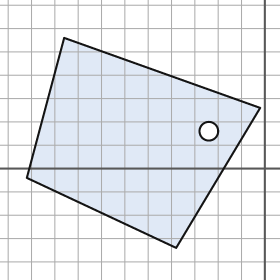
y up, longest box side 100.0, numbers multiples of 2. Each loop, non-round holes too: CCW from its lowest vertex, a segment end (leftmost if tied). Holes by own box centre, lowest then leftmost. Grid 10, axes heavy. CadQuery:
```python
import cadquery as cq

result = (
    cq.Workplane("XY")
    .moveTo(-38.0, -34.0)
    .lineTo(-2.0, 26.0)
    .lineTo(-86.0, 56.0)
    .lineTo(-102.0, -4.0)
    .close()
    .moveTo(-24.0, 16.0)
    .circle(4.0)
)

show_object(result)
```